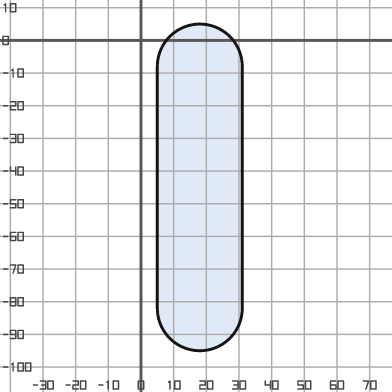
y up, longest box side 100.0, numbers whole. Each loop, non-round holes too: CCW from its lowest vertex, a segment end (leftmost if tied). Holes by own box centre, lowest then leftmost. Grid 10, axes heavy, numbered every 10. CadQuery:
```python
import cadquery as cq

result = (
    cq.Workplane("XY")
    .moveTo(5.0, -82.0)
    .threePointArc((18.0, -95.0), (31.0, -82.0))
    .lineTo(31.0, -8.0)
    .threePointArc((18.0, 5.0), (5.0, -8.0))
    .close()
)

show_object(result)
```